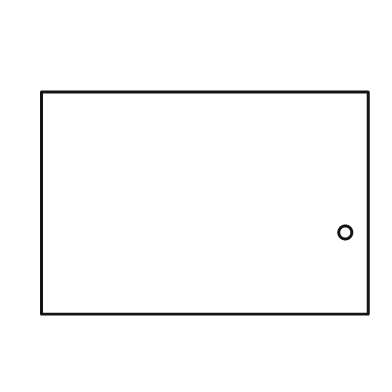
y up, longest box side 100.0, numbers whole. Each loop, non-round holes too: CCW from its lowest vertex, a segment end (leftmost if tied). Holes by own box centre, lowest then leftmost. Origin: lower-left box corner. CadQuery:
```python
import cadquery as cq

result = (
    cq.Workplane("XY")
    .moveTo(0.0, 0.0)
    .lineTo(100.0, 0.0)
    .lineTo(100.0, 68.0)
    .lineTo(0.0, 68.0)
    .close()
    .moveTo(93.0, 25.0)
    .circle(2.0)
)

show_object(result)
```